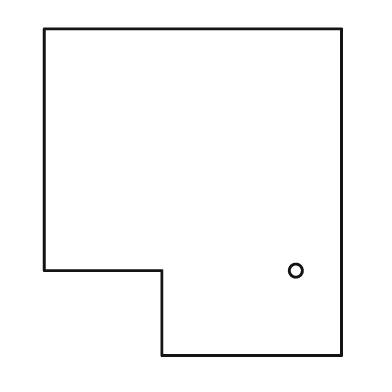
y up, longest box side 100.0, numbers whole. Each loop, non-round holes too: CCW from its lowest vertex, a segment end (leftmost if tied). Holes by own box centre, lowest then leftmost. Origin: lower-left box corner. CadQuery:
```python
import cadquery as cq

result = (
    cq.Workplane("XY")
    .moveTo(36.0, 0.0)
    .lineTo(91.0, 0.0)
    .lineTo(91.0, 100.0)
    .lineTo(0.0, 100.0)
    .lineTo(0.0, 26.0)
    .lineTo(36.0, 26.0)
    .close()
    .moveTo(77.0, 26.0)
    .circle(2.0)
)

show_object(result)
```